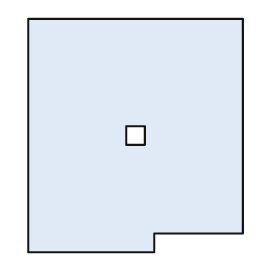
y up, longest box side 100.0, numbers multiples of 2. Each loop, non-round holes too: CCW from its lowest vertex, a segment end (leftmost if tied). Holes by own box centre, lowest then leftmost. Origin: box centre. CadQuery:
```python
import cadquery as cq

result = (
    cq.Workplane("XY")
    .moveTo(-46.0, -50.0)
    .lineTo(8.0, -50.0)
    .lineTo(8.0, -42.0)
    .lineTo(46.0, -42.0)
    .lineTo(46.0, 50.0)
    .lineTo(-46.0, 50.0)
    .close()
    .moveTo(-4.0, -4.0)
    .lineTo(4.0, -4.0)
    .lineTo(4.0, 4.0)
    .lineTo(-4.0, 4.0)
    .close()
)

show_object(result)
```